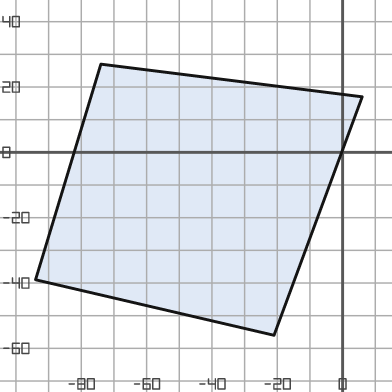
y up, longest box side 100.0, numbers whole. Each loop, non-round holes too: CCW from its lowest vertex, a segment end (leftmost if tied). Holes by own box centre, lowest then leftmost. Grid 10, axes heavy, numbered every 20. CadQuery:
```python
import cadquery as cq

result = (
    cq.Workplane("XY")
    .moveTo(-21.0, -56.0)
    .lineTo(6.0, 17.0)
    .lineTo(-74.0, 27.0)
    .lineTo(-94.0, -39.0)
    .close()
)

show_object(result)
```